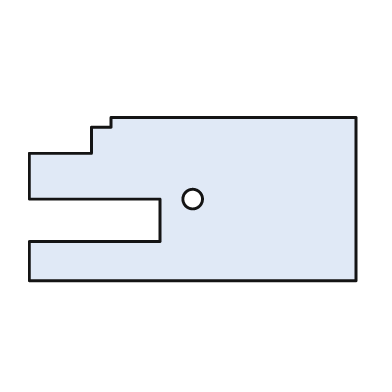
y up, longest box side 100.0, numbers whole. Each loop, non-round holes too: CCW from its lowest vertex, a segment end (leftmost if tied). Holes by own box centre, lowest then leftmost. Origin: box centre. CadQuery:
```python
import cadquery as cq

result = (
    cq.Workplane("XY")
    .moveTo(-50.0, -25.0)
    .lineTo(50.0, -25.0)
    .lineTo(50.0, 25.0)
    .lineTo(-25.0, 25.0)
    .lineTo(-25.0, 22.0)
    .lineTo(-31.0, 22.0)
    .lineTo(-31.0, 14.0)
    .lineTo(-50.0, 14.0)
    .lineTo(-50.0, 0.0)
    .lineTo(-10.0, 0.0)
    .lineTo(-10.0, -13.0)
    .lineTo(-50.0, -13.0)
    .close()
    .moveTo(0.0, 0.0)
    .circle(3.0)
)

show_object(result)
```